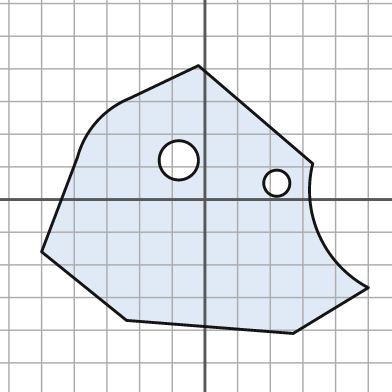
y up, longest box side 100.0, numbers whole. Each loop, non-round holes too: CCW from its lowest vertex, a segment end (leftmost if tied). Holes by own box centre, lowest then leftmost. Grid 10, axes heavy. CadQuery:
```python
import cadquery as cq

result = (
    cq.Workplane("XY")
    .moveTo(27.0, -41.0)
    .lineTo(50.0, -27.0)
    .threePointArc((35.0, -11.0), (33.0, 11.0))
    .lineTo(-2.0, 41.0)
    .lineTo(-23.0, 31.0)
    .threePointArc((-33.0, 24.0), (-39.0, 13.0))
    .lineTo(-50.0, -16.0)
    .lineTo(-24.0, -37.0)
    .close()
    .moveTo(22.0, 5.0)
    .circle(4.0)
    .moveTo(-8.0, 12.0)
    .circle(6.0)
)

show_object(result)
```